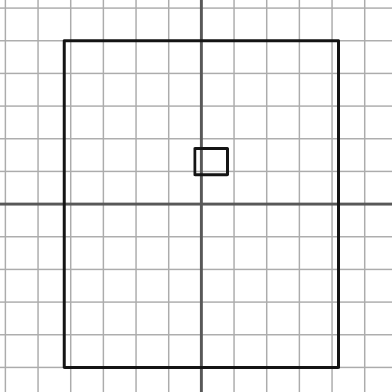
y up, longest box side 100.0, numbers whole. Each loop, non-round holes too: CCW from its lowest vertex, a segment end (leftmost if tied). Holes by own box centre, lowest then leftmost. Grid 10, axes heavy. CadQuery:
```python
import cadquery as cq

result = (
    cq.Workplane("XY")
    .moveTo(-42.0, -50.0)
    .lineTo(42.0, -50.0)
    .lineTo(42.0, 50.0)
    .lineTo(-42.0, 50.0)
    .close()
    .moveTo(-2.0, 9.0)
    .lineTo(8.0, 9.0)
    .lineTo(8.0, 17.0)
    .lineTo(-2.0, 17.0)
    .close()
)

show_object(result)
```